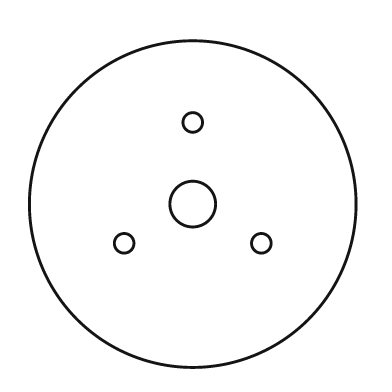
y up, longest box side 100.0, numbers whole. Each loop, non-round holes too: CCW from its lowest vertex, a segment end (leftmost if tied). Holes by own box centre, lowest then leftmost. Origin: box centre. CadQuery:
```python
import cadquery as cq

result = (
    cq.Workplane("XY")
    .moveTo(0.0, 0.0)
    .circle(50.0)
    .moveTo(-21.0, -12.0)
    .circle(3.0)
    .moveTo(21.0, -12.0)
    .circle(3.0)
    .moveTo(0.0, 0.0)
    .circle(7.0)
    .moveTo(0.0, 25.0)
    .circle(3.0)
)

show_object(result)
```